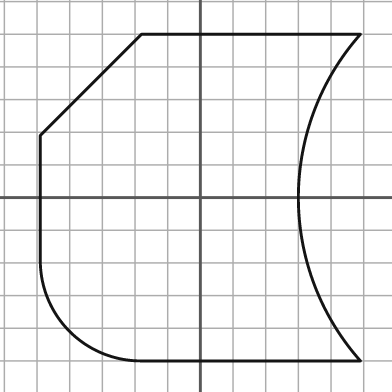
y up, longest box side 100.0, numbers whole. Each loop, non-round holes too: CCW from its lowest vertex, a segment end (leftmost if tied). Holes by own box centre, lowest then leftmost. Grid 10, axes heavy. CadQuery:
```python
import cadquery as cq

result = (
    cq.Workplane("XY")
    .moveTo(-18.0, -50.0)
    .lineTo(49.0, -50.0)
    .threePointArc((30.0, 0.0), (49.0, 50.0))
    .lineTo(-18.0, 50.0)
    .lineTo(-49.0, 19.0)
    .lineTo(-49.0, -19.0)
    .threePointArc((-40.0, -41.0), (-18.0, -50.0))
    .close()
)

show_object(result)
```